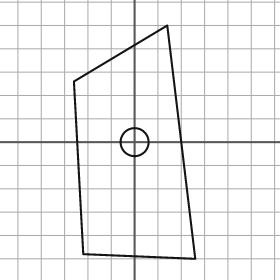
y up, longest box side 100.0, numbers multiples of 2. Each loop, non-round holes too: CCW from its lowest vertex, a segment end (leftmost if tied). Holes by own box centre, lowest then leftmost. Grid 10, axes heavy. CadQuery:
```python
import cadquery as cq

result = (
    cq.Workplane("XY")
    .moveTo(26.0, -50.0)
    .lineTo(14.0, 50.0)
    .lineTo(-26.0, 26.0)
    .lineTo(-22.0, -48.0)
    .close()
    .moveTo(0.0, 0.0)
    .circle(6.0)
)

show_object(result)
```